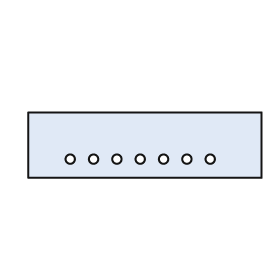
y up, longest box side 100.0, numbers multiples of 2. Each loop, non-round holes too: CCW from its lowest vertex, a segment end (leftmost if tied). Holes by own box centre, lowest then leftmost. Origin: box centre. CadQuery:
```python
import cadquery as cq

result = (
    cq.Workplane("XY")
    .moveTo(-50.0, -14.0)
    .lineTo(50.0, -14.0)
    .lineTo(50.0, 14.0)
    .lineTo(-50.0, 14.0)
    .close()
    .moveTo(-32.0, -6.0)
    .circle(2.0)
    .moveTo(-22.0, -6.0)
    .circle(2.0)
    .moveTo(-12.0, -6.0)
    .circle(2.0)
    .moveTo(-2.0, -6.0)
    .circle(2.0)
    .moveTo(8.0, -6.0)
    .circle(2.0)
    .moveTo(18.0, -6.0)
    .circle(2.0)
    .moveTo(28.0, -6.0)
    .circle(2.0)
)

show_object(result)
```